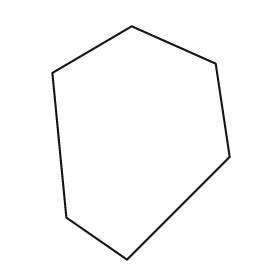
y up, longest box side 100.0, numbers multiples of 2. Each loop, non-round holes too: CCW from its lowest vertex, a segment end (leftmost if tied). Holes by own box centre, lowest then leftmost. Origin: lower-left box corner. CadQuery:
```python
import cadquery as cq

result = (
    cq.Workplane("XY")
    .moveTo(32.0, 0.0)
    .lineTo(76.0, 44.0)
    .lineTo(70.0, 84.0)
    .lineTo(34.0, 100.0)
    .lineTo(0.0, 80.0)
    .lineTo(6.0, 18.0)
    .close()
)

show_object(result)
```